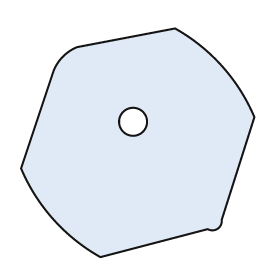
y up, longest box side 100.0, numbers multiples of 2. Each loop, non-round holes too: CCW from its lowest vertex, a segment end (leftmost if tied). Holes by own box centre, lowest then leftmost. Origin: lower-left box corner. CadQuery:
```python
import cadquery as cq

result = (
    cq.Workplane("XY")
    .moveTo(34.0, 0.0)
    .lineTo(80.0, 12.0)
    .threePointArc((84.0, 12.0), (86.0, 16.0))
    .lineTo(100.0, 60.0)
    .threePointArc((86.0, 82.0), (66.0, 98.0))
    .lineTo(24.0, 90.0)
    .threePointArc((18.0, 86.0), (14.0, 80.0))
    .lineTo(0.0, 38.0)
    .threePointArc((14.0, 16.0), (34.0, 0.0))
    .close()
    .moveTo(48.0, 58.0)
    .circle(6.0)
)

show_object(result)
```